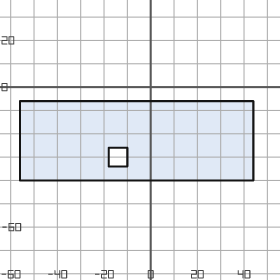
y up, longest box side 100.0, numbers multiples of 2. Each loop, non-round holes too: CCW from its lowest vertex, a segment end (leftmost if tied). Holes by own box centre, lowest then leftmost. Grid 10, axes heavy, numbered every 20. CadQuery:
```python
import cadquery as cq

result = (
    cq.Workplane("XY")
    .moveTo(-56.0, -40.0)
    .lineTo(44.0, -40.0)
    .lineTo(44.0, -6.0)
    .lineTo(-56.0, -6.0)
    .close()
    .moveTo(-18.0, -34.0)
    .lineTo(-10.0, -34.0)
    .lineTo(-10.0, -26.0)
    .lineTo(-18.0, -26.0)
    .close()
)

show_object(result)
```